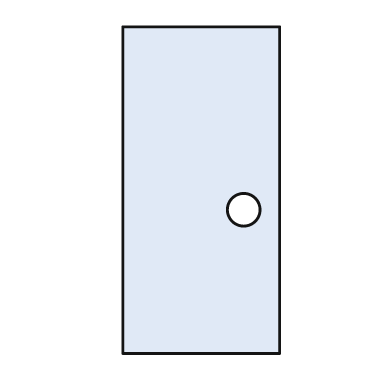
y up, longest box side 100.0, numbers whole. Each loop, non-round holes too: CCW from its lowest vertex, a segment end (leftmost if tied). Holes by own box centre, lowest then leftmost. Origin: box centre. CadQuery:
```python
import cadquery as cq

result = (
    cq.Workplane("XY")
    .moveTo(-24.0, -50.0)
    .lineTo(24.0, -50.0)
    .lineTo(24.0, 50.0)
    .lineTo(-24.0, 50.0)
    .close()
    .moveTo(13.0, -6.0)
    .circle(5.0)
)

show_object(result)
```